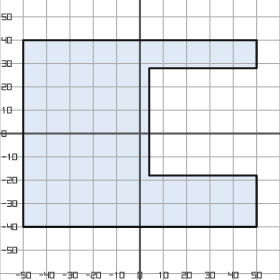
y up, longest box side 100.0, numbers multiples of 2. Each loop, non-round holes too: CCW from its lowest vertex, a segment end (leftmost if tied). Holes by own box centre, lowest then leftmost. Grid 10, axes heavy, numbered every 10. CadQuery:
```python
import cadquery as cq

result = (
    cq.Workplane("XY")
    .moveTo(-50.0, -40.0)
    .lineTo(50.0, -40.0)
    .lineTo(50.0, -18.0)
    .lineTo(4.0, -18.0)
    .lineTo(4.0, 28.0)
    .lineTo(50.0, 28.0)
    .lineTo(50.0, 40.0)
    .lineTo(-50.0, 40.0)
    .close()
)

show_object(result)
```